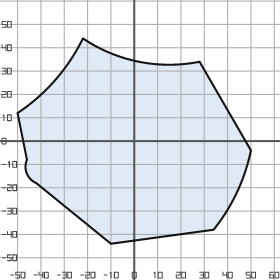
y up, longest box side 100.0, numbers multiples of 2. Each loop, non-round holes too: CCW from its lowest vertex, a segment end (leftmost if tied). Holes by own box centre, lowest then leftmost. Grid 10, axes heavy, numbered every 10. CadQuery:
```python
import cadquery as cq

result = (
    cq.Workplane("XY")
    .moveTo(-10.0, -44.0)
    .lineTo(34.0, -38.0)
    .threePointArc((44.0, -22.0), (50.0, -4.0))
    .lineTo(28.0, 34.0)
    .threePointArc((2.0, 34.0), (-22.0, 44.0))
    .threePointArc((-34.0, 26.0), (-50.0, 12.0))
    .lineTo(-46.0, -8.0)
    .threePointArc((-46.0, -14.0), (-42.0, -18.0))
    .close()
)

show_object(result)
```